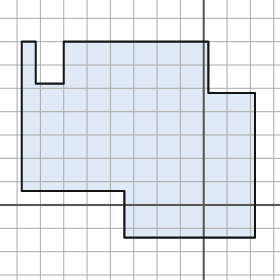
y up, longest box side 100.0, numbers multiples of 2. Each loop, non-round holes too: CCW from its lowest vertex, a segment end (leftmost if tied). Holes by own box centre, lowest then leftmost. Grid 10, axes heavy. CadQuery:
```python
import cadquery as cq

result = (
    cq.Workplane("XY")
    .moveTo(-34.0, -14.0)
    .lineTo(22.0, -14.0)
    .lineTo(22.0, 48.0)
    .lineTo(2.0, 48.0)
    .lineTo(2.0, 70.0)
    .lineTo(-60.0, 70.0)
    .lineTo(-60.0, 52.0)
    .lineTo(-72.0, 52.0)
    .lineTo(-72.0, 70.0)
    .lineTo(-78.0, 70.0)
    .lineTo(-78.0, 6.0)
    .lineTo(-34.0, 6.0)
    .close()
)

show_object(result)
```